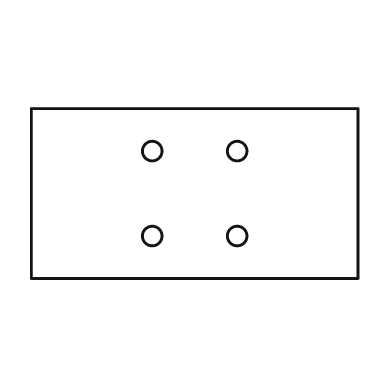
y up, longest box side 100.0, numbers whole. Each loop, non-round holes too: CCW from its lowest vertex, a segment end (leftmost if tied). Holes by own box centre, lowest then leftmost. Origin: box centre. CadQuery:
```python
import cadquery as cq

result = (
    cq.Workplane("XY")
    .moveTo(-50.0, -26.0)
    .lineTo(50.0, -26.0)
    .lineTo(50.0, 26.0)
    .lineTo(-50.0, 26.0)
    .close()
    .moveTo(-13.0, -13.0)
    .circle(3.0)
    .moveTo(13.0, -13.0)
    .circle(3.0)
    .moveTo(-13.0, 13.0)
    .circle(3.0)
    .moveTo(13.0, 13.0)
    .circle(3.0)
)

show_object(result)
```